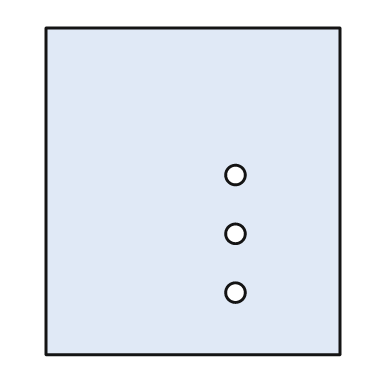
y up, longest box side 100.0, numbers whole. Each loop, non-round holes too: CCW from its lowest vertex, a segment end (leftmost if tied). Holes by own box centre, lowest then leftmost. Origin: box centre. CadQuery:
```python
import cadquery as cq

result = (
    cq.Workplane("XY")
    .moveTo(-45.0, -50.0)
    .lineTo(45.0, -50.0)
    .lineTo(45.0, 50.0)
    .lineTo(-45.0, 50.0)
    .close()
    .moveTo(13.0, -31.0)
    .circle(3.0)
    .moveTo(13.0, -13.0)
    .circle(3.0)
    .moveTo(13.0, 5.0)
    .circle(3.0)
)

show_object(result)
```